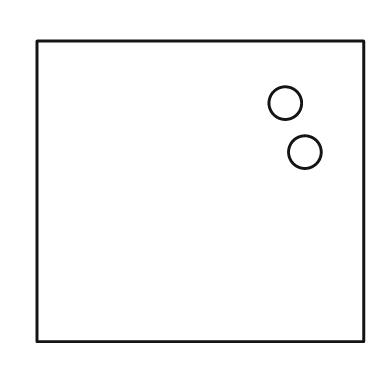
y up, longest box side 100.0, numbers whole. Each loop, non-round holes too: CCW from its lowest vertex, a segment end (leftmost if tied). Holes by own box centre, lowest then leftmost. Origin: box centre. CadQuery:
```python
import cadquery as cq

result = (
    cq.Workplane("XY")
    .moveTo(-50.0, -46.0)
    .lineTo(50.0, -46.0)
    .lineTo(50.0, 46.0)
    .lineTo(-50.0, 46.0)
    .close()
    .moveTo(32.0, 12.0)
    .circle(5.0)
    .moveTo(26.0, 27.0)
    .circle(5.0)
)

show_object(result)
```